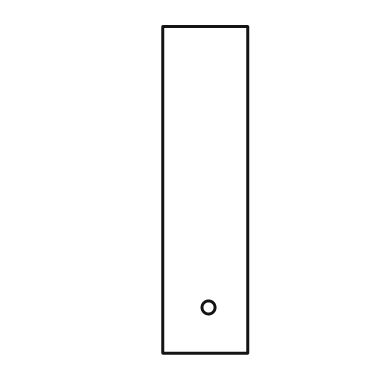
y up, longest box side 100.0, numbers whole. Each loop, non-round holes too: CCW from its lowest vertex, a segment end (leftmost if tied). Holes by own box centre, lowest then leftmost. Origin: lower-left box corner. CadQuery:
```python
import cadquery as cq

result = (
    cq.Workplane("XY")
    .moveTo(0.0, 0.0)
    .lineTo(26.0, 0.0)
    .lineTo(26.0, 100.0)
    .lineTo(0.0, 100.0)
    .close()
    .moveTo(14.0, 14.0)
    .circle(2.0)
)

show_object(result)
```